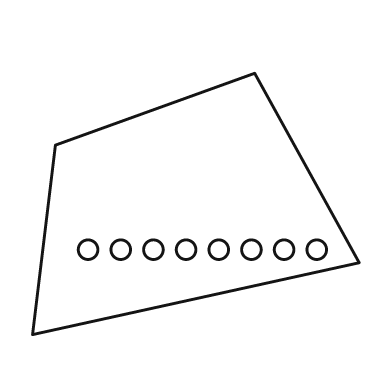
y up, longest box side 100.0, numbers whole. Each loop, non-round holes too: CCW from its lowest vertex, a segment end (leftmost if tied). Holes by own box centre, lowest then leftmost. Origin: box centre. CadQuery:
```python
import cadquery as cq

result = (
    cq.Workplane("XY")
    .moveTo(-50.0, -40.0)
    .lineTo(50.0, -18.0)
    .lineTo(18.0, 40.0)
    .lineTo(-43.0, 18.0)
    .close()
    .moveTo(-33.0, -14.0)
    .circle(3.0)
    .moveTo(-23.0, -14.0)
    .circle(3.0)
    .moveTo(-13.0, -14.0)
    .circle(3.0)
    .moveTo(-3.0, -14.0)
    .circle(3.0)
    .moveTo(7.0, -14.0)
    .circle(3.0)
    .moveTo(17.0, -14.0)
    .circle(3.0)
    .moveTo(27.0, -14.0)
    .circle(3.0)
    .moveTo(37.0, -14.0)
    .circle(3.0)
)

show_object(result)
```